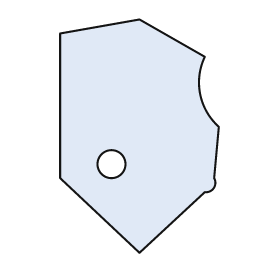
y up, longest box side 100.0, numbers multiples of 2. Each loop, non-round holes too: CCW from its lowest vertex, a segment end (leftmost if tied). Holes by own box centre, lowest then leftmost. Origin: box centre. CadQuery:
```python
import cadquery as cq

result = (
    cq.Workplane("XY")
    .moveTo(0.0, -50.0)
    .lineTo(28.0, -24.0)
    .threePointArc((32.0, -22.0), (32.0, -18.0))
    .lineTo(34.0, 4.0)
    .threePointArc((26.0, 18.0), (28.0, 34.0))
    .lineTo(0.0, 50.0)
    .lineTo(-34.0, 44.0)
    .lineTo(-34.0, -18.0)
    .close()
    .moveTo(-12.0, -12.0)
    .circle(6.0)
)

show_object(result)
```